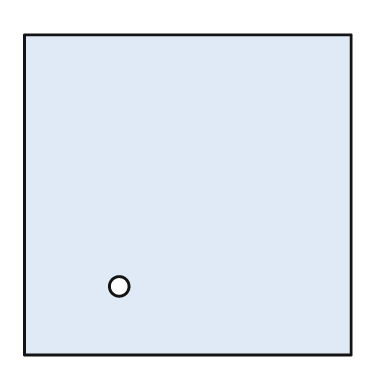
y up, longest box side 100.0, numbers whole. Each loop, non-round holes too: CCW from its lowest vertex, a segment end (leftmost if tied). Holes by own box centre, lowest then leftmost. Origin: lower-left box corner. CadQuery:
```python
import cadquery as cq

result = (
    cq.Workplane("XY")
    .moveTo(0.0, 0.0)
    .lineTo(100.0, 0.0)
    .lineTo(100.0, 98.0)
    .lineTo(0.0, 98.0)
    .close()
    .moveTo(29.0, 21.0)
    .circle(3.0)
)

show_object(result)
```